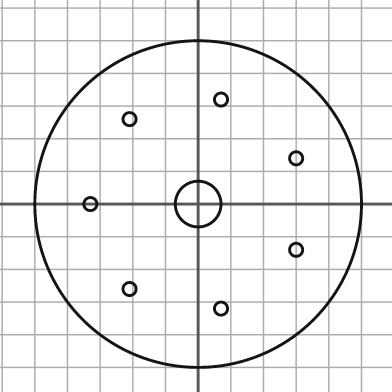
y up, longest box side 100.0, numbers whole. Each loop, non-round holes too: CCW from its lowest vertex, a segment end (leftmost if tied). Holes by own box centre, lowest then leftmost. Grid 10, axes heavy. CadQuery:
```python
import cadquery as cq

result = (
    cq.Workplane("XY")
    .moveTo(0.0, 0.0)
    .circle(50.0)
    .moveTo(7.0, -32.0)
    .circle(2.0)
    .moveTo(-21.0, -26.0)
    .circle(2.0)
    .moveTo(30.0, -14.0)
    .circle(2.0)
    .moveTo(-33.0, 0.0)
    .circle(2.0)
    .moveTo(0.0, 0.0)
    .circle(7.0)
    .moveTo(30.0, 14.0)
    .circle(2.0)
    .moveTo(-21.0, 26.0)
    .circle(2.0)
    .moveTo(7.0, 32.0)
    .circle(2.0)
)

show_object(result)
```